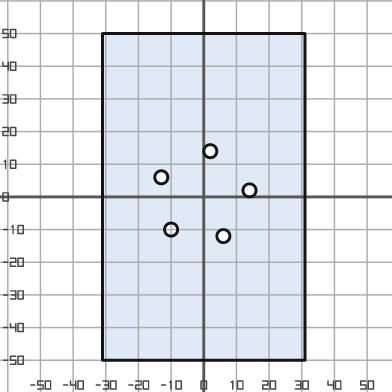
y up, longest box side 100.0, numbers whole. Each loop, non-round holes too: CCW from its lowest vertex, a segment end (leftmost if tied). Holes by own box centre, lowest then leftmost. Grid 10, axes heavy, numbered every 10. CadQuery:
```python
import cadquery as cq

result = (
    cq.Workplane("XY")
    .moveTo(-31.0, -50.0)
    .lineTo(31.0, -50.0)
    .lineTo(31.0, 50.0)
    .lineTo(-31.0, 50.0)
    .close()
    .moveTo(6.0, -12.0)
    .circle(2.0)
    .moveTo(-10.0, -10.0)
    .circle(2.0)
    .moveTo(14.0, 2.0)
    .circle(2.0)
    .moveTo(-13.0, 6.0)
    .circle(2.0)
    .moveTo(2.0, 14.0)
    .circle(2.0)
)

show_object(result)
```